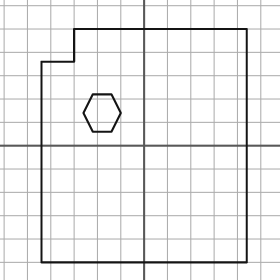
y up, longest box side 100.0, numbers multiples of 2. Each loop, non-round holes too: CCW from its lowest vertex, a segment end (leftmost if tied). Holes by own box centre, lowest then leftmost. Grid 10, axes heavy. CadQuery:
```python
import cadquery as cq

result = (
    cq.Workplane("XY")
    .moveTo(-44.0, -50.0)
    .lineTo(44.0, -50.0)
    .lineTo(44.0, 50.0)
    .lineTo(-30.0, 50.0)
    .lineTo(-30.0, 36.0)
    .lineTo(-44.0, 36.0)
    .close()
    .moveTo(-22.0, 6.0)
    .lineTo(-14.0, 6.0)
    .lineTo(-10.0, 14.0)
    .lineTo(-14.0, 22.0)
    .lineTo(-22.0, 22.0)
    .lineTo(-26.0, 14.0)
    .close()
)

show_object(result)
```